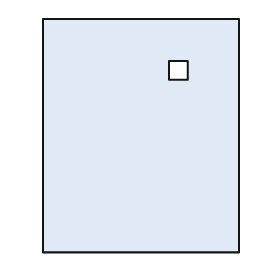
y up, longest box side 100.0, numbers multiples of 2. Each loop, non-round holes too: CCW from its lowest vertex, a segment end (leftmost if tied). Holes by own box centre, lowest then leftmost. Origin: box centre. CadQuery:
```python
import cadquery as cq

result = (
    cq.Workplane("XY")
    .moveTo(-42.0, -50.0)
    .lineTo(42.0, -50.0)
    .lineTo(42.0, 50.0)
    .lineTo(-42.0, 50.0)
    .close()
    .moveTo(12.0, 24.0)
    .lineTo(20.0, 24.0)
    .lineTo(20.0, 32.0)
    .lineTo(12.0, 32.0)
    .close()
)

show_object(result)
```